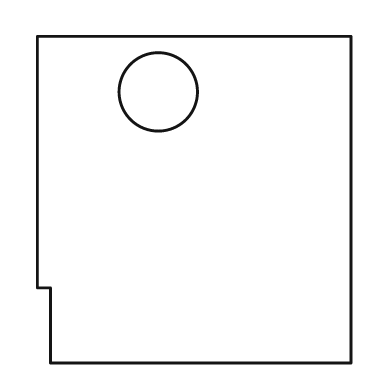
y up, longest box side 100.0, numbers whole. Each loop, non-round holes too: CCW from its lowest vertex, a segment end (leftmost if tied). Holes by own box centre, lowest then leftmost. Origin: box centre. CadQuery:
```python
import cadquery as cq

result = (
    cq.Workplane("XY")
    .moveTo(-44.0, -50.0)
    .lineTo(48.0, -50.0)
    .lineTo(48.0, 50.0)
    .lineTo(-48.0, 50.0)
    .lineTo(-48.0, -27.0)
    .lineTo(-44.0, -27.0)
    .close()
    .moveTo(-11.0, 33.0)
    .circle(12.0)
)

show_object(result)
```